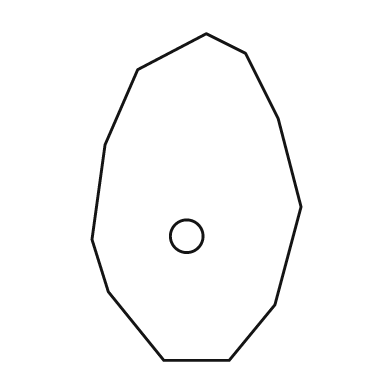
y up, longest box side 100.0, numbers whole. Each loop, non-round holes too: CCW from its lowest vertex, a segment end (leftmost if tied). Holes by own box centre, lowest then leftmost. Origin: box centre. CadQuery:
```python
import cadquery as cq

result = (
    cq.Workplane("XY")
    .moveTo(-10.0, -50.0)
    .lineTo(10.0, -50.0)
    .lineTo(24.0, -33.0)
    .lineTo(32.0, -3.0)
    .lineTo(25.0, 24.0)
    .lineTo(15.0, 44.0)
    .lineTo(3.0, 50.0)
    .lineTo(-18.0, 39.0)
    .lineTo(-28.0, 16.0)
    .lineTo(-32.0, -13.0)
    .lineTo(-27.0, -29.0)
    .close()
    .moveTo(-3.0, -12.0)
    .circle(5.0)
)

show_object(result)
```